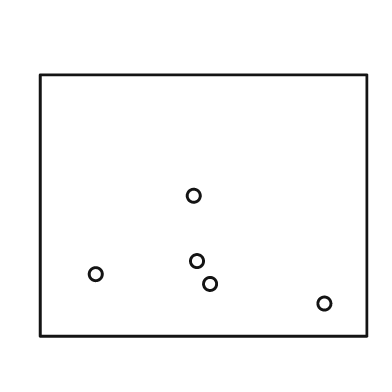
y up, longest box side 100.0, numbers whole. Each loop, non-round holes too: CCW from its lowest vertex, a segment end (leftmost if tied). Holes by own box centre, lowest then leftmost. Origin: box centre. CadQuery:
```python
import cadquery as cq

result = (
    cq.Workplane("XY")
    .moveTo(-50.0, -40.0)
    .lineTo(50.0, -40.0)
    .lineTo(50.0, 40.0)
    .lineTo(-50.0, 40.0)
    .close()
    .moveTo(37.0, -30.0)
    .circle(2.0)
    .moveTo(2.0, -24.0)
    .circle(2.0)
    .moveTo(-33.0, -21.0)
    .circle(2.0)
    .moveTo(-2.0, -17.0)
    .circle(2.0)
    .moveTo(-3.0, 3.0)
    .circle(2.0)
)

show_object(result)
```